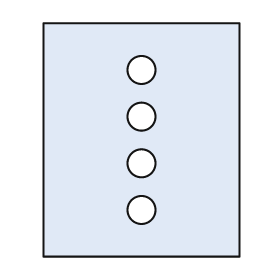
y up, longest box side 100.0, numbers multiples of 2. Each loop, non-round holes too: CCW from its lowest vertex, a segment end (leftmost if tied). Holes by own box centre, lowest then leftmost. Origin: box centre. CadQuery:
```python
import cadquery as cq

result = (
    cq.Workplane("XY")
    .moveTo(-42.0, -50.0)
    .lineTo(42.0, -50.0)
    .lineTo(42.0, 50.0)
    .lineTo(-42.0, 50.0)
    .close()
    .moveTo(0.0, -30.0)
    .circle(6.0)
    .moveTo(0.0, -10.0)
    .circle(6.0)
    .moveTo(0.0, 10.0)
    .circle(6.0)
    .moveTo(0.0, 30.0)
    .circle(6.0)
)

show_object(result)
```